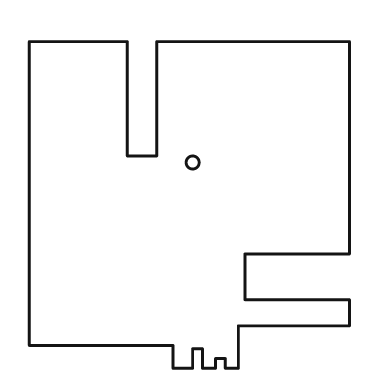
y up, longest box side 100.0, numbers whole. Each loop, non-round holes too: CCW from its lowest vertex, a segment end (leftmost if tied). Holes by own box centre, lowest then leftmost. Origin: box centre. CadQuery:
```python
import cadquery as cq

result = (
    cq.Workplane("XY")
    .moveTo(-5.0, -50.0)
    .lineTo(1.0, -50.0)
    .lineTo(1.0, -44.0)
    .lineTo(4.0, -44.0)
    .lineTo(4.0, -50.0)
    .lineTo(8.0, -50.0)
    .lineTo(8.0, -47.0)
    .lineTo(11.0, -47.0)
    .lineTo(11.0, -50.0)
    .lineTo(15.0, -50.0)
    .lineTo(15.0, -37.0)
    .lineTo(49.0, -37.0)
    .lineTo(49.0, -29.0)
    .lineTo(17.0, -29.0)
    .lineTo(17.0, -15.0)
    .lineTo(49.0, -15.0)
    .lineTo(49.0, 50.0)
    .lineTo(-10.0, 50.0)
    .lineTo(-10.0, 15.0)
    .lineTo(-19.0, 15.0)
    .lineTo(-19.0, 50.0)
    .lineTo(-49.0, 50.0)
    .lineTo(-49.0, -43.0)
    .lineTo(-5.0, -43.0)
    .close()
    .moveTo(1.0, 13.0)
    .circle(2.0)
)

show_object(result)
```